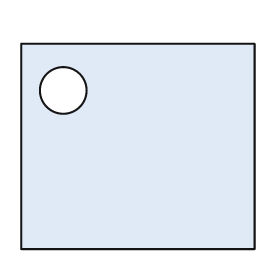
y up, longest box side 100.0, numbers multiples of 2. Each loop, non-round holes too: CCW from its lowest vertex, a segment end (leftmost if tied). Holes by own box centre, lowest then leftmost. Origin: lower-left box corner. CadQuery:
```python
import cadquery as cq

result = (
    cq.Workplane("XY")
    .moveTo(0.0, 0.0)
    .lineTo(100.0, 0.0)
    .lineTo(100.0, 88.0)
    .lineTo(0.0, 88.0)
    .close()
    .moveTo(18.0, 68.0)
    .circle(10.0)
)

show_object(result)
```